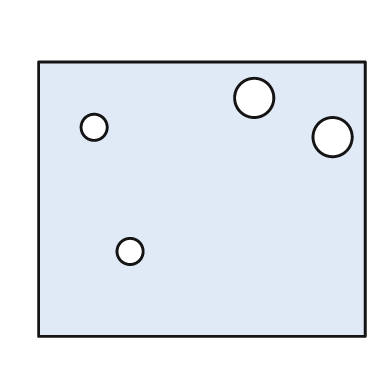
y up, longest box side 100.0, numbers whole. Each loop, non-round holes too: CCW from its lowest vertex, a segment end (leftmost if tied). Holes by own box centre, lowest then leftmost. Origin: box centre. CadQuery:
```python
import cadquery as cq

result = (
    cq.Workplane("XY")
    .moveTo(-50.0, -42.0)
    .lineTo(50.0, -42.0)
    .lineTo(50.0, 42.0)
    .lineTo(-50.0, 42.0)
    .close()
    .moveTo(-22.0, -16.0)
    .circle(4.0)
    .moveTo(40.0, 19.0)
    .circle(6.0)
    .moveTo(-33.0, 22.0)
    .circle(4.0)
    .moveTo(16.0, 31.0)
    .circle(6.0)
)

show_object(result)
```